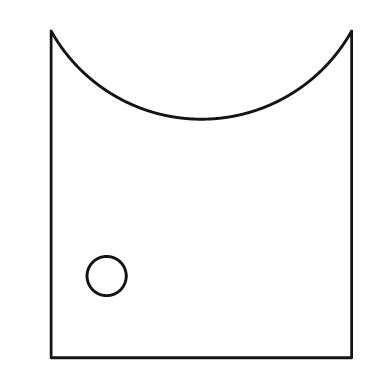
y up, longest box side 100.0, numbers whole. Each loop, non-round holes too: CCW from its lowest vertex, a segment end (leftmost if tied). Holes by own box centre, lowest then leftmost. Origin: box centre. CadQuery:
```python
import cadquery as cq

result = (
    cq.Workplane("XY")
    .moveTo(-46.0, -50.0)
    .lineTo(46.0, -50.0)
    .lineTo(46.0, 50.0)
    .threePointArc((0.0, 23.0), (-46.0, 50.0))
    .close()
    .moveTo(-29.0, -25.0)
    .circle(6.0)
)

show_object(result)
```